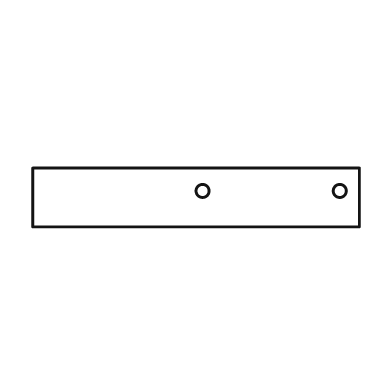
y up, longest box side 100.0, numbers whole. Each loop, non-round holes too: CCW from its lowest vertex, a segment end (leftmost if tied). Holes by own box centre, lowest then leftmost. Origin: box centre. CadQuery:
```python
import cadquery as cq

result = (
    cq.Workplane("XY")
    .moveTo(-50.0, -9.0)
    .lineTo(50.0, -9.0)
    .lineTo(50.0, 9.0)
    .lineTo(-50.0, 9.0)
    .close()
    .moveTo(2.0, 2.0)
    .circle(2.0)
    .moveTo(44.0, 2.0)
    .circle(2.0)
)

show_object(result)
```